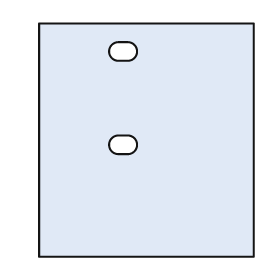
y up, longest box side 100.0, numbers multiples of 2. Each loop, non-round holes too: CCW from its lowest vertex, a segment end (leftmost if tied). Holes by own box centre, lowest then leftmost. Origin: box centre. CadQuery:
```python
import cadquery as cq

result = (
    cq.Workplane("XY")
    .moveTo(-46.0, -50.0)
    .lineTo(46.0, -50.0)
    .lineTo(46.0, 50.0)
    .lineTo(-46.0, 50.0)
    .close()
    .moveTo(-12.0, -6.0)
    .lineTo(-8.0, -6.0)
    .threePointArc((-4.0, -2.0), (-8.0, 2.0))
    .lineTo(-12.0, 2.0)
    .threePointArc((-16.0, -2.0), (-12.0, -6.0))
    .close()
    .moveTo(-12.0, 34.0)
    .lineTo(-8.0, 34.0)
    .threePointArc((-4.0, 38.0), (-8.0, 42.0))
    .lineTo(-12.0, 42.0)
    .threePointArc((-16.0, 38.0), (-12.0, 34.0))
    .close()
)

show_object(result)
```